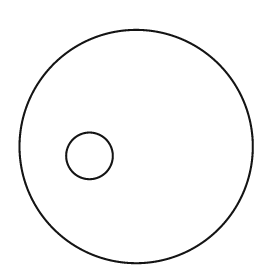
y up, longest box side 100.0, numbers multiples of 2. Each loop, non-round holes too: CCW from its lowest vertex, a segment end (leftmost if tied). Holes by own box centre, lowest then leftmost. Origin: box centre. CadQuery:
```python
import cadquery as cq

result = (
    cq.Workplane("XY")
    .moveTo(0.0, 0.0)
    .circle(50.0)
    .moveTo(-20.0, -4.0)
    .circle(10.0)
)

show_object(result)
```